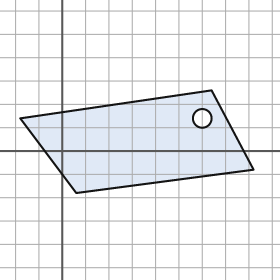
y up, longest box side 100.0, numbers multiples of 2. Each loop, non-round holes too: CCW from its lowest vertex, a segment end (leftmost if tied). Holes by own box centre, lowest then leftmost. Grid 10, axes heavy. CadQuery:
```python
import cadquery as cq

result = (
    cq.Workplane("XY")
    .moveTo(6.0, -18.0)
    .lineTo(82.0, -8.0)
    .lineTo(64.0, 26.0)
    .lineTo(-18.0, 14.0)
    .close()
    .moveTo(60.0, 14.0)
    .circle(4.0)
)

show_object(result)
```